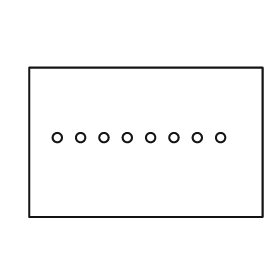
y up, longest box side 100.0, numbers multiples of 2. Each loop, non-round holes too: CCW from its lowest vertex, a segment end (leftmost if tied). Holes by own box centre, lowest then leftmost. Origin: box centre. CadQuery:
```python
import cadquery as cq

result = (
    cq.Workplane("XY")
    .moveTo(-50.0, -32.0)
    .lineTo(50.0, -32.0)
    .lineTo(50.0, 32.0)
    .lineTo(-50.0, 32.0)
    .close()
    .moveTo(-38.0, 2.0)
    .circle(2.0)
    .moveTo(-28.0, 2.0)
    .circle(2.0)
    .moveTo(-18.0, 2.0)
    .circle(2.0)
    .moveTo(-8.0, 2.0)
    .circle(2.0)
    .moveTo(2.0, 2.0)
    .circle(2.0)
    .moveTo(12.0, 2.0)
    .circle(2.0)
    .moveTo(22.0, 2.0)
    .circle(2.0)
    .moveTo(32.0, 2.0)
    .circle(2.0)
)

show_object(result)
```